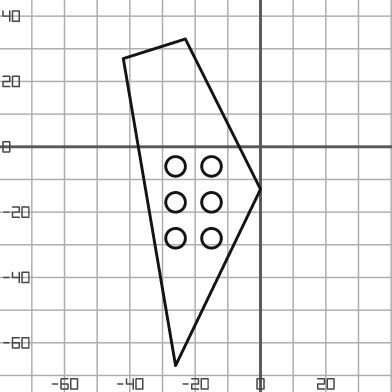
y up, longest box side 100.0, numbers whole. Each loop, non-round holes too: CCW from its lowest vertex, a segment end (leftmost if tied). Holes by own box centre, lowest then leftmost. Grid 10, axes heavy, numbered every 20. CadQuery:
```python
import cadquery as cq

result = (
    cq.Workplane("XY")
    .moveTo(-26.0, -67.0)
    .lineTo(0.0, -13.0)
    .lineTo(-23.0, 33.0)
    .lineTo(-42.0, 27.0)
    .close()
    .moveTo(-26.0, -28.0)
    .circle(3.0)
    .moveTo(-15.0, -28.0)
    .circle(3.0)
    .moveTo(-26.0, -17.0)
    .circle(3.0)
    .moveTo(-15.0, -17.0)
    .circle(3.0)
    .moveTo(-26.0, -6.0)
    .circle(3.0)
    .moveTo(-15.0, -6.0)
    .circle(3.0)
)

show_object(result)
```